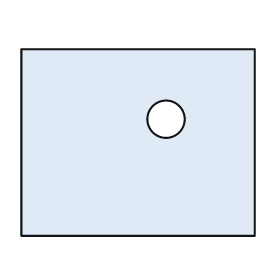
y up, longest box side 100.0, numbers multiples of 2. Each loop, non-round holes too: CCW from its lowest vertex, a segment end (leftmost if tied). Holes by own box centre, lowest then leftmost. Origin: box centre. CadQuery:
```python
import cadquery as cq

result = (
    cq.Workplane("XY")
    .moveTo(-50.0, -40.0)
    .lineTo(50.0, -40.0)
    .lineTo(50.0, 40.0)
    .lineTo(-50.0, 40.0)
    .close()
    .moveTo(12.0, 10.0)
    .circle(8.0)
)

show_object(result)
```